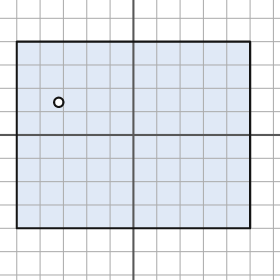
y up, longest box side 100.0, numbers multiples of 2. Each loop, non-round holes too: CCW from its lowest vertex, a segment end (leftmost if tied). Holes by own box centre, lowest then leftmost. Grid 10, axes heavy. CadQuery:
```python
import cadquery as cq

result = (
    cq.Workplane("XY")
    .moveTo(-50.0, -40.0)
    .lineTo(50.0, -40.0)
    .lineTo(50.0, 40.0)
    .lineTo(-50.0, 40.0)
    .close()
    .moveTo(-32.0, 14.0)
    .circle(2.0)
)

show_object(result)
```